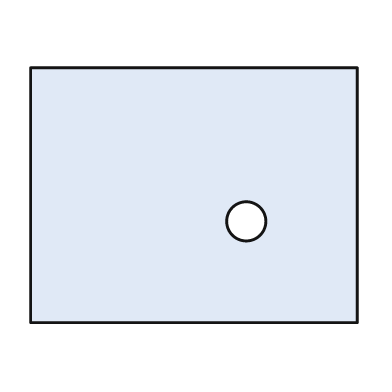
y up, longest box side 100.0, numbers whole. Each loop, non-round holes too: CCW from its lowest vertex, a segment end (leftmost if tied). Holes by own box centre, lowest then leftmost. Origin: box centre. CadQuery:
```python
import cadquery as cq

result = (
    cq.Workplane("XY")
    .moveTo(-50.0, -39.0)
    .lineTo(50.0, -39.0)
    .lineTo(50.0, 39.0)
    .lineTo(-50.0, 39.0)
    .close()
    .moveTo(16.0, -8.0)
    .circle(6.0)
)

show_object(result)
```